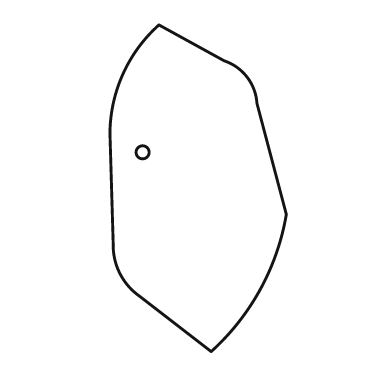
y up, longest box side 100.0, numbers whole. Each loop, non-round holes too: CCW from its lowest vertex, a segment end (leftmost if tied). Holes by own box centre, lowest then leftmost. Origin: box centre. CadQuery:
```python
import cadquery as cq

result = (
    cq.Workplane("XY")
    .moveTo(4.0, -50.0)
    .threePointArc((19.0, -31.0), (27.0, -8.0))
    .lineTo(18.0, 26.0)
    .threePointArc((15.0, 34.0), (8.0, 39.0))
    .lineTo(-12.0, 50.0)
    .threePointArc((-23.0, 35.0), (-27.0, 17.0))
    .lineTo(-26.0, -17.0)
    .threePointArc((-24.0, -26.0), (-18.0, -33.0))
    .close()
    .moveTo(-17.0, 11.0)
    .circle(2.0)
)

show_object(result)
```